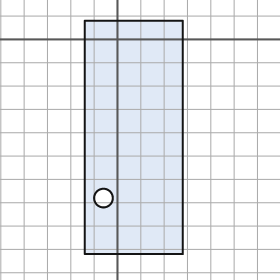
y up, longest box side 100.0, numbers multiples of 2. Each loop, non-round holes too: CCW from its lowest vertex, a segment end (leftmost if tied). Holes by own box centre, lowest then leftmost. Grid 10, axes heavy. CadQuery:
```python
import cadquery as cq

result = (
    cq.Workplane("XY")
    .moveTo(-14.0, -92.0)
    .lineTo(28.0, -92.0)
    .lineTo(28.0, 8.0)
    .lineTo(-14.0, 8.0)
    .close()
    .moveTo(-6.0, -68.0)
    .circle(4.0)
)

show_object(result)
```